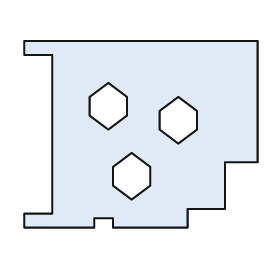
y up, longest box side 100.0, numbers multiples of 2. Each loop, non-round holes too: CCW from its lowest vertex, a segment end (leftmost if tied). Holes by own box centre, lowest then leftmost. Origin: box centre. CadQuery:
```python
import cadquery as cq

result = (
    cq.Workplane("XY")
    .moveTo(-50.0, -40.0)
    .lineTo(-20.0, -40.0)
    .lineTo(-20.0, -36.0)
    .lineTo(-12.0, -36.0)
    .lineTo(-12.0, -40.0)
    .lineTo(20.0, -40.0)
    .lineTo(20.0, -32.0)
    .lineTo(36.0, -32.0)
    .lineTo(36.0, -12.0)
    .lineTo(50.0, -12.0)
    .lineTo(50.0, 40.0)
    .lineTo(-50.0, 40.0)
    .lineTo(-50.0, 34.0)
    .lineTo(-38.0, 34.0)
    .lineTo(-38.0, -34.0)
    .lineTo(-50.0, -34.0)
    .close()
    .moveTo(-4.0, -28.0)
    .lineTo(4.0, -22.0)
    .lineTo(4.0, -14.0)
    .lineTo(-4.0, -8.0)
    .lineTo(-12.0, -14.0)
    .lineTo(-12.0, -22.0)
    .close()
    .moveTo(16.0, -4.0)
    .lineTo(24.0, 2.0)
    .lineTo(24.0, 10.0)
    .lineTo(16.0, 16.0)
    .lineTo(8.0, 10.0)
    .lineTo(8.0, 2.0)
    .close()
    .moveTo(-14.0, 2.0)
    .lineTo(-6.0, 8.0)
    .lineTo(-6.0, 16.0)
    .lineTo(-14.0, 22.0)
    .lineTo(-22.0, 16.0)
    .lineTo(-22.0, 8.0)
    .close()
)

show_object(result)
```